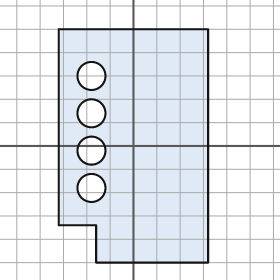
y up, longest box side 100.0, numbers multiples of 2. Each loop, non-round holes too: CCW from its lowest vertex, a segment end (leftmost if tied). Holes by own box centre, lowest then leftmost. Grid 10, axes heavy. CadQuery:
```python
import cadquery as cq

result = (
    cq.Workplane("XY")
    .moveTo(-16.0, -50.0)
    .lineTo(32.0, -50.0)
    .lineTo(32.0, 50.0)
    .lineTo(-32.0, 50.0)
    .lineTo(-32.0, -34.0)
    .lineTo(-16.0, -34.0)
    .close()
    .moveTo(-18.0, -18.0)
    .circle(6.0)
    .moveTo(-18.0, -2.0)
    .circle(6.0)
    .moveTo(-18.0, 14.0)
    .circle(6.0)
    .moveTo(-18.0, 30.0)
    .circle(6.0)
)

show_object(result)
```